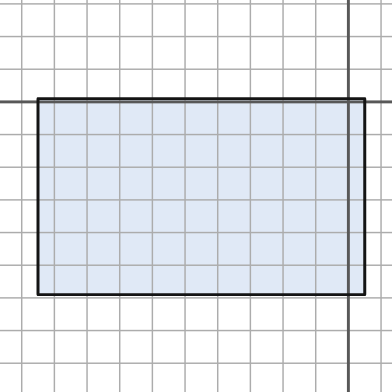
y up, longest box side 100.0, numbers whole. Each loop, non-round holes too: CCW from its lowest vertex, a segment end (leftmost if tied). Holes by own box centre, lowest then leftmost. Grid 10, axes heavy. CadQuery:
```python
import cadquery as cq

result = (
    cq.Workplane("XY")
    .moveTo(-95.0, -59.0)
    .lineTo(5.0, -59.0)
    .lineTo(5.0, 1.0)
    .lineTo(-95.0, 1.0)
    .close()
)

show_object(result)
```